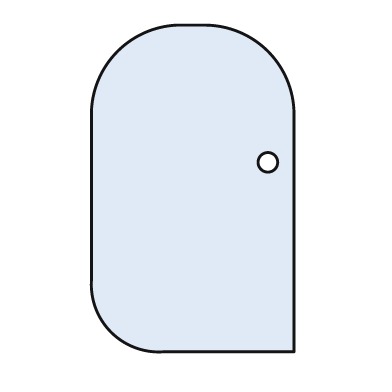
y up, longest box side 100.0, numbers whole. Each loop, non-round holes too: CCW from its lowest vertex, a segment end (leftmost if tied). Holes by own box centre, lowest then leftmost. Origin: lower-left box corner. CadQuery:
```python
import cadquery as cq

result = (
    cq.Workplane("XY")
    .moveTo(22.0, 0.0)
    .lineTo(62.0, 0.0)
    .lineTo(62.0, 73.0)
    .threePointArc((54.0, 92.0), (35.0, 100.0))
    .lineTo(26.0, 100.0)
    .threePointArc((8.0, 92.0), (0.0, 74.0))
    .lineTo(0.0, 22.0)
    .threePointArc((6.0, 6.0), (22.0, 0.0))
    .close()
    .moveTo(54.0, 58.0)
    .circle(3.0)
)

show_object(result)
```